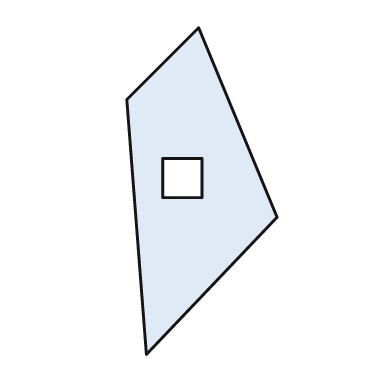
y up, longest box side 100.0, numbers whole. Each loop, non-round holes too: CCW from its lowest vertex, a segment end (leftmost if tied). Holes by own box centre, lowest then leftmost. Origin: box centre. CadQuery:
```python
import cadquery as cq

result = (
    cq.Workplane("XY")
    .moveTo(-17.0, -50.0)
    .lineTo(23.0, -8.0)
    .lineTo(-1.0, 50.0)
    .lineTo(-23.0, 28.0)
    .close()
    .moveTo(-12.0, -2.0)
    .lineTo(0.0, -2.0)
    .lineTo(0.0, 10.0)
    .lineTo(-12.0, 10.0)
    .close()
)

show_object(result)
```